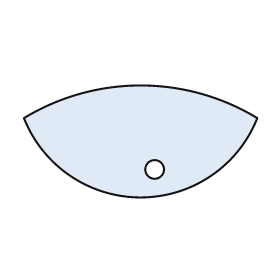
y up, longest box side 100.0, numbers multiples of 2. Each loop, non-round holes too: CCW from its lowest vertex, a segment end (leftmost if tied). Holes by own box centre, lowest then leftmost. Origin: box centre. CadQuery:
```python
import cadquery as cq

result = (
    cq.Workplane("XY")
    .moveTo(-50.0, 10.0)
    .threePointArc((0.0, -24.0), (50.0, 10.0))
    .threePointArc((0.0, 24.0), (-50.0, 10.0))
    .close()
    .moveTo(6.0, -12.0)
    .circle(4.0)
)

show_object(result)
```